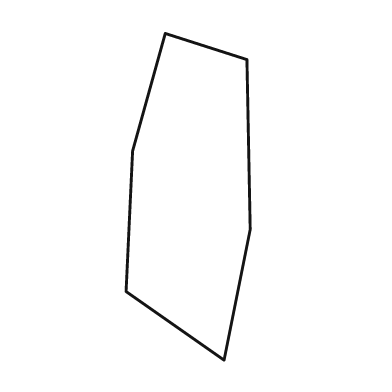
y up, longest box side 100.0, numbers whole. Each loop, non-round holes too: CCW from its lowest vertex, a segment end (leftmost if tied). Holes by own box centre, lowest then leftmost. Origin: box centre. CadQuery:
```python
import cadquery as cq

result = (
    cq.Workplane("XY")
    .moveTo(11.0, -50.0)
    .lineTo(19.0, -10.0)
    .lineTo(18.0, 42.0)
    .lineTo(-7.0, 50.0)
    .lineTo(-17.0, 14.0)
    .lineTo(-19.0, -29.0)
    .close()
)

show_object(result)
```